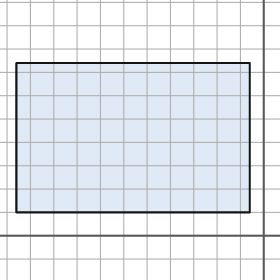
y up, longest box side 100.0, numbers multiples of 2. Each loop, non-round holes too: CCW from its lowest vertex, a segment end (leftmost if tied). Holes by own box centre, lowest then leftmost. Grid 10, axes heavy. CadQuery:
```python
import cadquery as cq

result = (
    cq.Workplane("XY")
    .moveTo(-106.0, 10.0)
    .lineTo(-6.0, 10.0)
    .lineTo(-6.0, 74.0)
    .lineTo(-106.0, 74.0)
    .close()
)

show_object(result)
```